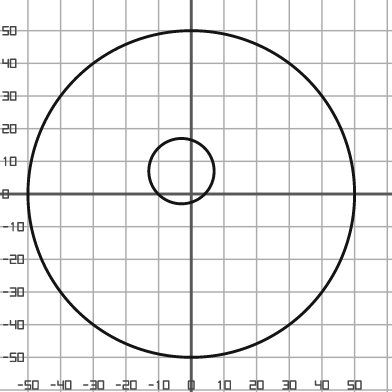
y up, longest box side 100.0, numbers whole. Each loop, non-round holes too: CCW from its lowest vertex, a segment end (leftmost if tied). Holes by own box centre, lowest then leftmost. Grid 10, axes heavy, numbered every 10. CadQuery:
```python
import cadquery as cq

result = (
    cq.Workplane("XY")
    .moveTo(0.0, 0.0)
    .circle(50.0)
    .moveTo(-3.0, 7.0)
    .circle(10.0)
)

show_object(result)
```